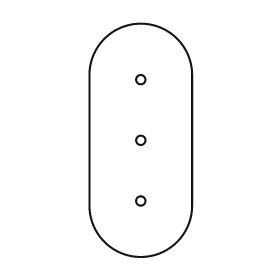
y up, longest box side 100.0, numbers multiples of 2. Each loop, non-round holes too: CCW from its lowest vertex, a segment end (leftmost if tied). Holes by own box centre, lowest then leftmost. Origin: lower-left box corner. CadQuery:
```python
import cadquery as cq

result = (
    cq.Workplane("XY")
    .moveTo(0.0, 22.0)
    .threePointArc((22.0, 0.0), (44.0, 22.0))
    .lineTo(44.0, 78.0)
    .threePointArc((22.0, 100.0), (0.0, 78.0))
    .close()
    .moveTo(22.0, 24.0)
    .circle(2.0)
    .moveTo(22.0, 50.0)
    .circle(2.0)
    .moveTo(22.0, 76.0)
    .circle(2.0)
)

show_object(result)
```